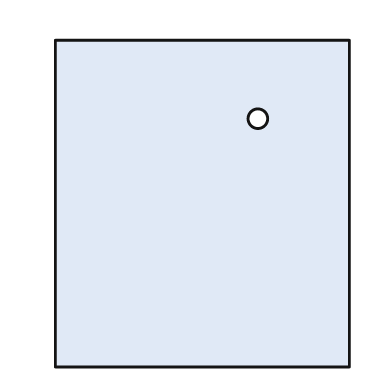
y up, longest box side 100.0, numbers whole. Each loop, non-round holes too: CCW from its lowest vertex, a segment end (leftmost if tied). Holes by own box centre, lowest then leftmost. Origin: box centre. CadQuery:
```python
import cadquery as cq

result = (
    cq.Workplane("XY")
    .moveTo(-45.0, -50.0)
    .lineTo(45.0, -50.0)
    .lineTo(45.0, 50.0)
    .lineTo(-45.0, 50.0)
    .close()
    .moveTo(17.0, 26.0)
    .circle(3.0)
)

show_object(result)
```